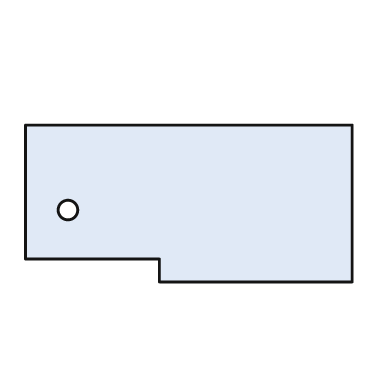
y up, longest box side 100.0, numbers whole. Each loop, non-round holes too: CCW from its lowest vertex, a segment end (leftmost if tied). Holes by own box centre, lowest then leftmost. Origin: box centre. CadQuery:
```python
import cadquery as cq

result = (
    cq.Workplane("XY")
    .moveTo(-9.0, -24.0)
    .lineTo(50.0, -24.0)
    .lineTo(50.0, 24.0)
    .lineTo(-50.0, 24.0)
    .lineTo(-50.0, -17.0)
    .lineTo(-9.0, -17.0)
    .close()
    .moveTo(-37.0, -2.0)
    .circle(3.0)
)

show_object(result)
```